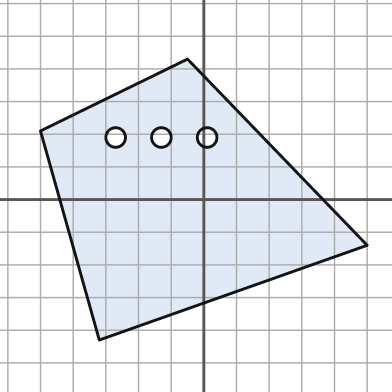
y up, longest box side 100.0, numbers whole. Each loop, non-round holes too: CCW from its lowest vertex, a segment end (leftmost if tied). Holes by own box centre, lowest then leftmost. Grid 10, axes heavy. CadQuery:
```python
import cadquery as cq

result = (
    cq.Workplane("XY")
    .moveTo(-32.0, -43.0)
    .lineTo(50.0, -14.0)
    .lineTo(-5.0, 43.0)
    .lineTo(-50.0, 21.0)
    .close()
    .moveTo(-27.0, 19.0)
    .circle(3.0)
    .moveTo(-13.0, 19.0)
    .circle(3.0)
    .moveTo(1.0, 19.0)
    .circle(3.0)
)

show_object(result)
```